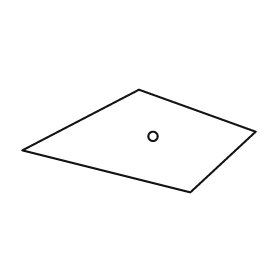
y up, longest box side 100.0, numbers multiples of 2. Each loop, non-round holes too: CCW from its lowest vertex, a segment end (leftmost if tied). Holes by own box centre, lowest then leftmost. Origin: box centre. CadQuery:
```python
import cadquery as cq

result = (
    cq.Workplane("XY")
    .moveTo(22.0, -22.0)
    .lineTo(50.0, 4.0)
    .lineTo(0.0, 22.0)
    .lineTo(-50.0, -4.0)
    .close()
    .moveTo(6.0, 2.0)
    .circle(2.0)
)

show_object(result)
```